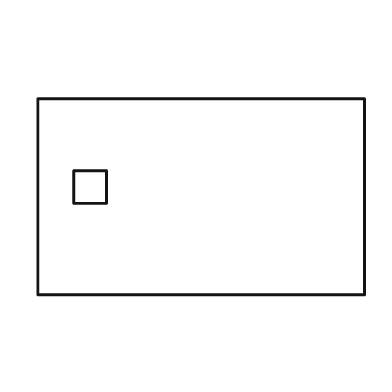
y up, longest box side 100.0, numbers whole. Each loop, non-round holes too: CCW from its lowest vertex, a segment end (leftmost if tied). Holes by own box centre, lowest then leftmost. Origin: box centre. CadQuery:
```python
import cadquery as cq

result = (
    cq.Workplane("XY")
    .moveTo(-50.0, -30.0)
    .lineTo(50.0, -30.0)
    .lineTo(50.0, 30.0)
    .lineTo(-50.0, 30.0)
    .close()
    .moveTo(-39.0, -2.0)
    .lineTo(-29.0, -2.0)
    .lineTo(-29.0, 8.0)
    .lineTo(-39.0, 8.0)
    .close()
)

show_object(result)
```